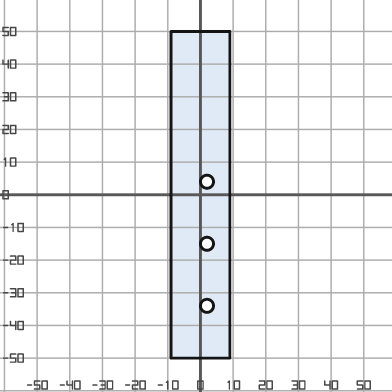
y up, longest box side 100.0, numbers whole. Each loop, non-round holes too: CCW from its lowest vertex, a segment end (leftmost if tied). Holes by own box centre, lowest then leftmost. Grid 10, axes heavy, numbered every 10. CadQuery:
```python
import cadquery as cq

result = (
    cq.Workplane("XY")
    .moveTo(-9.0, -50.0)
    .lineTo(9.0, -50.0)
    .lineTo(9.0, 50.0)
    .lineTo(-9.0, 50.0)
    .close()
    .moveTo(2.0, -34.0)
    .circle(2.0)
    .moveTo(2.0, -15.0)
    .circle(2.0)
    .moveTo(2.0, 4.0)
    .circle(2.0)
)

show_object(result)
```